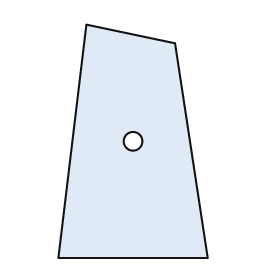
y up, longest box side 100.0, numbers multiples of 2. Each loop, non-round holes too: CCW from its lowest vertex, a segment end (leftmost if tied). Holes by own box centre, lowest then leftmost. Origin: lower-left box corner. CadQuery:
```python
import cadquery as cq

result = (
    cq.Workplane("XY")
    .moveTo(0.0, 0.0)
    .lineTo(64.0, 0.0)
    .lineTo(50.0, 92.0)
    .lineTo(12.0, 100.0)
    .close()
    .moveTo(32.0, 50.0)
    .circle(4.0)
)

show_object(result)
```